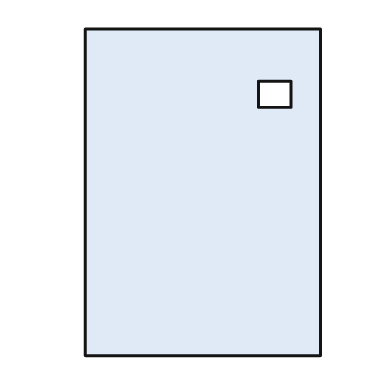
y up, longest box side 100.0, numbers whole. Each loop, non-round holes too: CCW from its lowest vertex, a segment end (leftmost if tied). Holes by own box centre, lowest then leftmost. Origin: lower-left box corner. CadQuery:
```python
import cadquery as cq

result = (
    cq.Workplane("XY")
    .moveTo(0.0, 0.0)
    .lineTo(72.0, 0.0)
    .lineTo(72.0, 100.0)
    .lineTo(0.0, 100.0)
    .close()
    .moveTo(53.0, 76.0)
    .lineTo(63.0, 76.0)
    .lineTo(63.0, 84.0)
    .lineTo(53.0, 84.0)
    .close()
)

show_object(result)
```